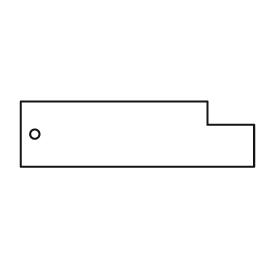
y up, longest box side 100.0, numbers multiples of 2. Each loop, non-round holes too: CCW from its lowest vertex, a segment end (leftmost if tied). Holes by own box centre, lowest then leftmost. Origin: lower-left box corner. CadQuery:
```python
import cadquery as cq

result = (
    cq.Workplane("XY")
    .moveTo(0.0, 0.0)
    .lineTo(100.0, 0.0)
    .lineTo(100.0, 18.0)
    .lineTo(80.0, 18.0)
    .lineTo(80.0, 28.0)
    .lineTo(0.0, 28.0)
    .close()
    .moveTo(6.0, 14.0)
    .circle(2.0)
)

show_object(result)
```